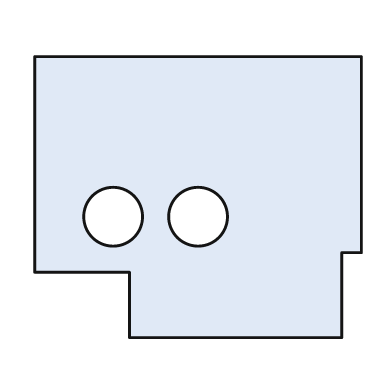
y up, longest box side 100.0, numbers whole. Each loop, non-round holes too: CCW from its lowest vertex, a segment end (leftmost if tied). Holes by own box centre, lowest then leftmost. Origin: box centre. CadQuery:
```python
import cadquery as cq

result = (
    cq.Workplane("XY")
    .moveTo(-21.0, -43.0)
    .lineTo(44.0, -43.0)
    .lineTo(44.0, -17.0)
    .lineTo(50.0, -17.0)
    .lineTo(50.0, 43.0)
    .lineTo(-50.0, 43.0)
    .lineTo(-50.0, -23.0)
    .lineTo(-21.0, -23.0)
    .close()
    .moveTo(-26.0, -6.0)
    .circle(9.0)
    .moveTo(0.0, -6.0)
    .circle(9.0)
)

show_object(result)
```